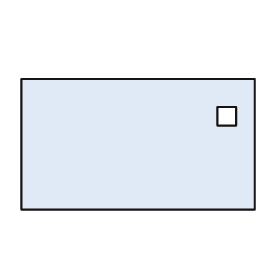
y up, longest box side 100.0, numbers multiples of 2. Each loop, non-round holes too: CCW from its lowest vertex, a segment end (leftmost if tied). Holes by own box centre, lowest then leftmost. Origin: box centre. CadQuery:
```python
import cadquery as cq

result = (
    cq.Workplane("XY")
    .moveTo(-50.0, -28.0)
    .lineTo(50.0, -28.0)
    .lineTo(50.0, 28.0)
    .lineTo(-50.0, 28.0)
    .close()
    .moveTo(34.0, 8.0)
    .lineTo(42.0, 8.0)
    .lineTo(42.0, 16.0)
    .lineTo(34.0, 16.0)
    .close()
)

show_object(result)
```